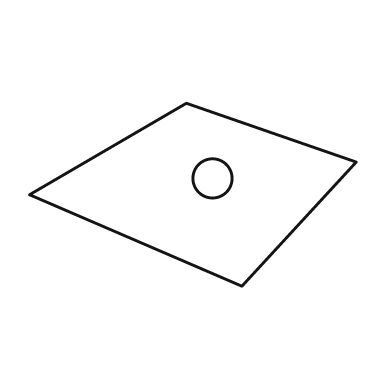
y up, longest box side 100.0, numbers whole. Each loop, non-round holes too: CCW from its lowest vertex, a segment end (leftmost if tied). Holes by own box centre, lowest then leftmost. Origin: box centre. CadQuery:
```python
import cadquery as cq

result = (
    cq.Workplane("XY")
    .moveTo(15.0, -28.0)
    .lineTo(50.0, 10.0)
    .lineTo(-2.0, 28.0)
    .lineTo(-50.0, 0.0)
    .close()
    .moveTo(6.0, 5.0)
    .circle(6.0)
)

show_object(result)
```